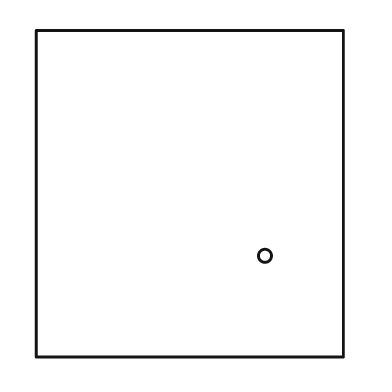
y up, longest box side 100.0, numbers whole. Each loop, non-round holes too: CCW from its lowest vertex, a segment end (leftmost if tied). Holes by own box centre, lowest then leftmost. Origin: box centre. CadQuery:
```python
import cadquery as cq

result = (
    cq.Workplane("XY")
    .moveTo(-47.0, -50.0)
    .lineTo(47.0, -50.0)
    .lineTo(47.0, 50.0)
    .lineTo(-47.0, 50.0)
    .close()
    .moveTo(23.0, -19.0)
    .circle(2.0)
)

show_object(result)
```